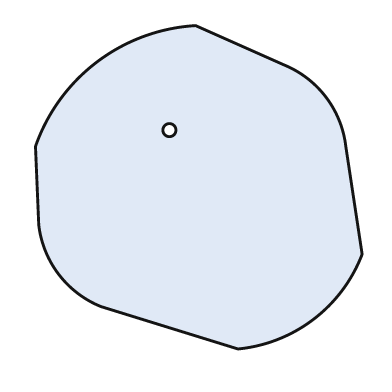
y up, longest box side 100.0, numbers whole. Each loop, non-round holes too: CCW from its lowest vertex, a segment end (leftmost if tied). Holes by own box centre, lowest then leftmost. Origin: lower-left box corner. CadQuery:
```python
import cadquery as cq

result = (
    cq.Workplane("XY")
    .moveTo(62.0, 0.0)
    .threePointArc((85.0, 9.0), (100.0, 29.0))
    .lineTo(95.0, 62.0)
    .threePointArc((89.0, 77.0), (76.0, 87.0))
    .lineTo(49.0, 99.0)
    .threePointArc((19.0, 88.0), (0.0, 62.0))
    .lineTo(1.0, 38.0)
    .threePointArc((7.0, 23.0), (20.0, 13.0))
    .close()
    .moveTo(41.0, 67.0)
    .circle(2.0)
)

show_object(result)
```